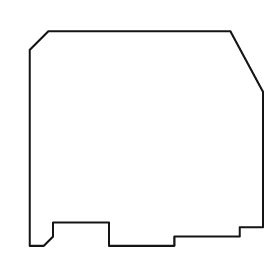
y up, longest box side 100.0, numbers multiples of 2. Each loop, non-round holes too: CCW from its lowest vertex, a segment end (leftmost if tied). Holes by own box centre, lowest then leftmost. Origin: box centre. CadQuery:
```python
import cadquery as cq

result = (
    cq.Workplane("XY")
    .moveTo(-50.0, -46.0)
    .lineTo(-44.0, -46.0)
    .lineTo(-40.0, -42.0)
    .lineTo(-40.0, -36.0)
    .lineTo(-16.0, -36.0)
    .lineTo(-16.0, -46.0)
    .lineTo(12.0, -46.0)
    .lineTo(12.0, -42.0)
    .lineTo(40.0, -42.0)
    .lineTo(40.0, -38.0)
    .lineTo(50.0, -38.0)
    .lineTo(50.0, 20.0)
    .lineTo(36.0, 46.0)
    .lineTo(-42.0, 46.0)
    .lineTo(-50.0, 38.0)
    .close()
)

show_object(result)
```